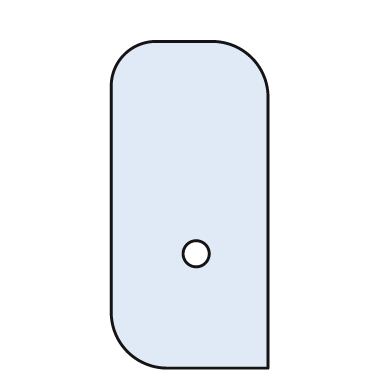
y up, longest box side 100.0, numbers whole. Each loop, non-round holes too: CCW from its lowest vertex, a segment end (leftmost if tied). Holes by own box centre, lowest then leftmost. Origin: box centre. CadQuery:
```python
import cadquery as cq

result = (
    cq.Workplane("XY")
    .moveTo(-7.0, -50.0)
    .lineTo(24.0, -50.0)
    .lineTo(24.0, 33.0)
    .threePointArc((19.0, 45.0), (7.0, 50.0))
    .lineTo(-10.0, 50.0)
    .threePointArc((-20.0, 46.0), (-24.0, 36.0))
    .lineTo(-24.0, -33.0)
    .threePointArc((-19.0, -45.0), (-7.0, -50.0))
    .close()
    .moveTo(2.0, -15.0)
    .circle(4.0)
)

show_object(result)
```